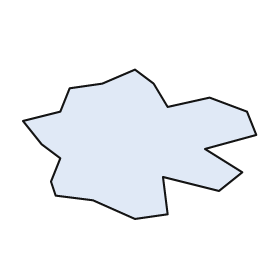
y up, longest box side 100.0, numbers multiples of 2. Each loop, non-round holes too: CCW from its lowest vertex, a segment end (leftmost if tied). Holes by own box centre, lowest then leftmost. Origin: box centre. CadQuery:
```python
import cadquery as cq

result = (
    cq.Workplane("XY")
    .moveTo(-2.0, -32.0)
    .lineTo(12.0, -30.0)
    .lineTo(10.0, -14.0)
    .lineTo(34.0, -20.0)
    .lineTo(44.0, -12.0)
    .lineTo(28.0, -2.0)
    .lineTo(50.0, 4.0)
    .lineTo(46.0, 14.0)
    .lineTo(30.0, 20.0)
    .lineTo(12.0, 16.0)
    .lineTo(6.0, 26.0)
    .lineTo(-2.0, 32.0)
    .lineTo(-16.0, 26.0)
    .lineTo(-30.0, 24.0)
    .lineTo(-34.0, 14.0)
    .lineTo(-50.0, 10.0)
    .lineTo(-42.0, 0.0)
    .lineTo(-34.0, -6.0)
    .lineTo(-38.0, -16.0)
    .lineTo(-36.0, -22.0)
    .lineTo(-20.0, -24.0)
    .close()
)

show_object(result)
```